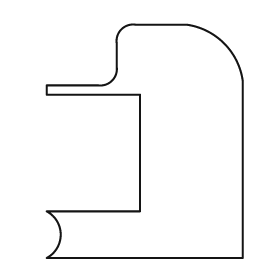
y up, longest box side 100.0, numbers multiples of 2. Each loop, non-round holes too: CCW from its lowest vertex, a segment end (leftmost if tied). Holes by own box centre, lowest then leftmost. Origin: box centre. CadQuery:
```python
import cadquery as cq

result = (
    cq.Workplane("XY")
    .moveTo(-42.0, -50.0)
    .lineTo(42.0, -50.0)
    .lineTo(42.0, 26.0)
    .threePointArc((34.0, 42.0), (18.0, 50.0))
    .lineTo(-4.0, 50.0)
    .threePointArc((-10.0, 48.0), (-12.0, 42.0))
    .lineTo(-12.0, 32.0)
    .threePointArc((-14.0, 26.0), (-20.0, 24.0))
    .lineTo(-42.0, 24.0)
    .lineTo(-42.0, 20.0)
    .lineTo(-2.0, 20.0)
    .lineTo(-2.0, -30.0)
    .lineTo(-42.0, -30.0)
    .threePointArc((-36.0, -40.0), (-42.0, -50.0))
    .close()
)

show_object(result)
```